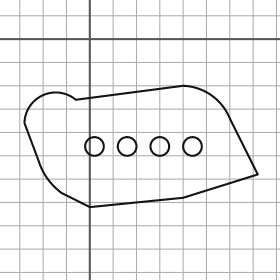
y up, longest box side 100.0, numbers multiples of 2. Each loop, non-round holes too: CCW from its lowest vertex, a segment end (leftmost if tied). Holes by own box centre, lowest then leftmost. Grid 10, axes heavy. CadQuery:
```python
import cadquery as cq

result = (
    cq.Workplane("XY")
    .moveTo(0.0, -72.0)
    .lineTo(40.0, -68.0)
    .lineTo(72.0, -58.0)
    .lineTo(60.0, -34.0)
    .threePointArc((52.0, -24.0), (40.0, -20.0))
    .lineTo(-6.0, -26.0)
    .threePointArc((-20.0, -24.0), (-28.0, -36.0))
    .lineTo(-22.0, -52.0)
    .threePointArc((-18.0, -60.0), (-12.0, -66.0))
    .close()
    .moveTo(2.0, -46.0)
    .circle(4.0)
    .moveTo(16.0, -46.0)
    .circle(4.0)
    .moveTo(30.0, -46.0)
    .circle(4.0)
    .moveTo(44.0, -46.0)
    .circle(4.0)
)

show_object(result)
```